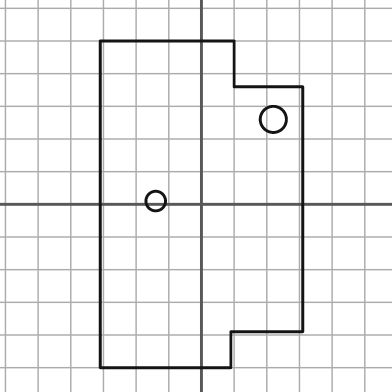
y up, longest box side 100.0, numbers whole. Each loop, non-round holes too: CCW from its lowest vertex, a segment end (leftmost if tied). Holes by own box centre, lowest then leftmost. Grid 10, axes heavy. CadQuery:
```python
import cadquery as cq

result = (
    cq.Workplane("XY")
    .moveTo(-31.0, -50.0)
    .lineTo(9.0, -50.0)
    .lineTo(9.0, -39.0)
    .lineTo(31.0, -39.0)
    .lineTo(31.0, 36.0)
    .lineTo(10.0, 36.0)
    .lineTo(10.0, 50.0)
    .lineTo(-31.0, 50.0)
    .close()
    .moveTo(-14.0, 1.0)
    .circle(3.0)
    .moveTo(22.0, 26.0)
    .circle(4.0)
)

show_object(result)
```